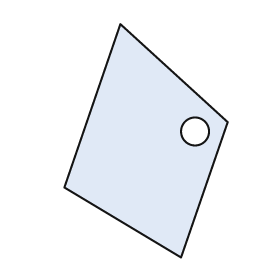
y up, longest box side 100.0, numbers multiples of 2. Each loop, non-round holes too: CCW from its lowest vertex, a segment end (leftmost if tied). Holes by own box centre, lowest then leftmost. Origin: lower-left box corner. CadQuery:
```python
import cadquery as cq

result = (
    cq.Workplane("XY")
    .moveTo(50.0, 0.0)
    .lineTo(70.0, 58.0)
    .lineTo(24.0, 100.0)
    .lineTo(0.0, 30.0)
    .close()
    .moveTo(56.0, 54.0)
    .circle(6.0)
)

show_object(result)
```